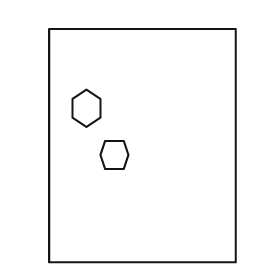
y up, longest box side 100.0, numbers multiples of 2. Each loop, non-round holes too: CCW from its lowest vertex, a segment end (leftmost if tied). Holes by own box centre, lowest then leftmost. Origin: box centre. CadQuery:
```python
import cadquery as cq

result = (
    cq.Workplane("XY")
    .moveTo(-40.0, -50.0)
    .lineTo(40.0, -50.0)
    .lineTo(40.0, 50.0)
    .lineTo(-40.0, 50.0)
    .close()
    .moveTo(-16.0, -10.0)
    .lineTo(-8.0, -10.0)
    .lineTo(-6.0, -4.0)
    .lineTo(-8.0, 2.0)
    .lineTo(-16.0, 2.0)
    .lineTo(-18.0, -4.0)
    .close()
    .moveTo(-24.0, 8.0)
    .lineTo(-18.0, 12.0)
    .lineTo(-18.0, 20.0)
    .lineTo(-24.0, 24.0)
    .lineTo(-30.0, 20.0)
    .lineTo(-30.0, 12.0)
    .close()
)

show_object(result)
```